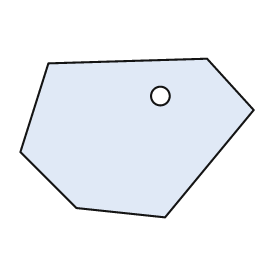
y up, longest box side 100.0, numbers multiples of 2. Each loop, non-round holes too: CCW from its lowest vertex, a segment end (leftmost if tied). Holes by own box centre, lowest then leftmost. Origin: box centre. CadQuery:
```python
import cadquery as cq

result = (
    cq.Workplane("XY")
    .moveTo(12.0, -34.0)
    .lineTo(50.0, 12.0)
    .lineTo(30.0, 34.0)
    .lineTo(-38.0, 32.0)
    .lineTo(-50.0, -6.0)
    .lineTo(-26.0, -30.0)
    .close()
    .moveTo(10.0, 18.0)
    .circle(4.0)
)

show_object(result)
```